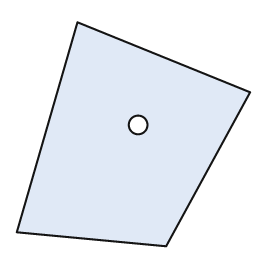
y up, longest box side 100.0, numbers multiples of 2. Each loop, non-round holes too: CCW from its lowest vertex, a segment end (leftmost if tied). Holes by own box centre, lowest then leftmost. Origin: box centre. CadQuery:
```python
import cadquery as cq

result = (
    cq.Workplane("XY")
    .moveTo(14.0, -48.0)
    .lineTo(50.0, 18.0)
    .lineTo(-24.0, 48.0)
    .lineTo(-50.0, -42.0)
    .close()
    .moveTo(2.0, 4.0)
    .circle(4.0)
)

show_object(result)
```